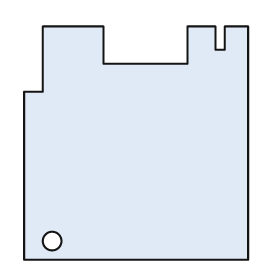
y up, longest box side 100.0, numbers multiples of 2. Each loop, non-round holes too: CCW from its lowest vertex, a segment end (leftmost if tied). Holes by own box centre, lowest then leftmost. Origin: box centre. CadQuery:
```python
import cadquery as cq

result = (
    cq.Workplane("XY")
    .moveTo(-48.0, -50.0)
    .lineTo(48.0, -50.0)
    .lineTo(48.0, 50.0)
    .lineTo(38.0, 50.0)
    .lineTo(38.0, 40.0)
    .lineTo(34.0, 40.0)
    .lineTo(34.0, 50.0)
    .lineTo(22.0, 50.0)
    .lineTo(22.0, 34.0)
    .lineTo(-14.0, 34.0)
    .lineTo(-14.0, 50.0)
    .lineTo(-40.0, 50.0)
    .lineTo(-40.0, 22.0)
    .lineTo(-48.0, 22.0)
    .close()
    .moveTo(-36.0, -42.0)
    .circle(4.0)
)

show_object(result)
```